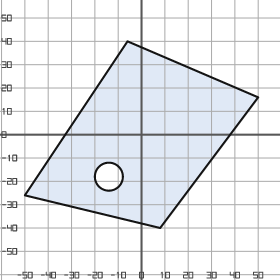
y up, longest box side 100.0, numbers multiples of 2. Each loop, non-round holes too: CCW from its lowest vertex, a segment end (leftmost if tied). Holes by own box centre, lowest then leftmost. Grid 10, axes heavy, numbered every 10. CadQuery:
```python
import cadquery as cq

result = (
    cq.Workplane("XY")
    .moveTo(8.0, -40.0)
    .lineTo(50.0, 16.0)
    .lineTo(-6.0, 40.0)
    .lineTo(-50.0, -26.0)
    .close()
    .moveTo(-14.0, -18.0)
    .circle(6.0)
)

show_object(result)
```